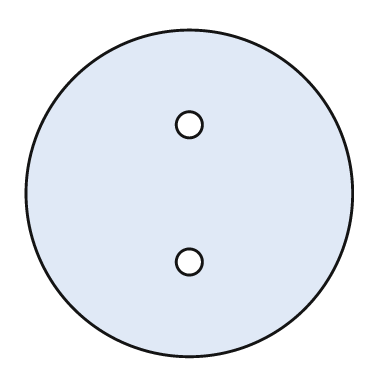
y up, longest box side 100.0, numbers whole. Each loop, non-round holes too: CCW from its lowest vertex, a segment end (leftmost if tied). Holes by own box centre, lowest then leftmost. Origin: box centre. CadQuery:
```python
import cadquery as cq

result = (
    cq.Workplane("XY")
    .moveTo(0.0, 0.0)
    .circle(50.0)
    .moveTo(0.0, -21.0)
    .circle(4.0)
    .moveTo(0.0, 21.0)
    .circle(4.0)
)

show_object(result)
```